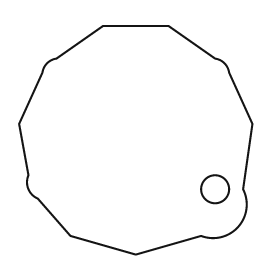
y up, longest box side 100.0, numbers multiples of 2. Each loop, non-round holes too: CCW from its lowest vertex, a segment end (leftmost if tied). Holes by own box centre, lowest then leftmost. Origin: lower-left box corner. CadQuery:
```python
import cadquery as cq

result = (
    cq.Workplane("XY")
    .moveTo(50.0, 0.0)
    .lineTo(78.0, 8.0)
    .threePointArc((94.0, 12.0), (96.0, 28.0))
    .lineTo(100.0, 56.0)
    .lineTo(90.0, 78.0)
    .threePointArc((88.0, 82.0), (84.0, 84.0))
    .lineTo(64.0, 98.0)
    .lineTo(36.0, 98.0)
    .lineTo(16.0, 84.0)
    .threePointArc((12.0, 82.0), (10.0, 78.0))
    .lineTo(0.0, 56.0)
    .lineTo(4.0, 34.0)
    .threePointArc((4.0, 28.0), (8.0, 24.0))
    .lineTo(22.0, 8.0)
    .close()
    .moveTo(84.0, 28.0)
    .circle(6.0)
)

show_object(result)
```